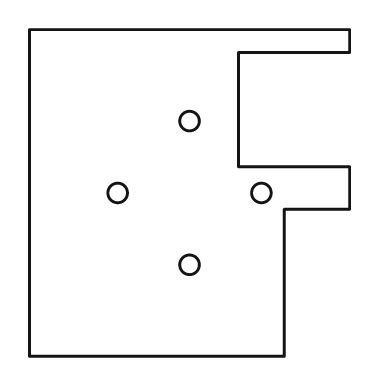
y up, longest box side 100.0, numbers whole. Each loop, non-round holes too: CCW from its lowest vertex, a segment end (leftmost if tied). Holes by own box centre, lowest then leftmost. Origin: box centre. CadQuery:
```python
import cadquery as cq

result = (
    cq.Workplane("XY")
    .moveTo(-49.0, -50.0)
    .lineTo(29.0, -50.0)
    .lineTo(29.0, -5.0)
    .lineTo(49.0, -5.0)
    .lineTo(49.0, 8.0)
    .lineTo(15.0, 8.0)
    .lineTo(15.0, 43.0)
    .lineTo(49.0, 43.0)
    .lineTo(49.0, 50.0)
    .lineTo(-49.0, 50.0)
    .close()
    .moveTo(0.0, -22.0)
    .circle(3.0)
    .moveTo(-22.0, 0.0)
    .circle(3.0)
    .moveTo(22.0, 0.0)
    .circle(3.0)
    .moveTo(0.0, 22.0)
    .circle(3.0)
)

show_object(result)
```